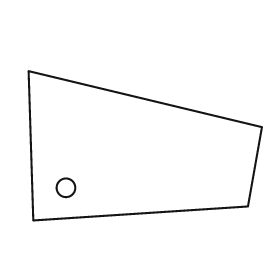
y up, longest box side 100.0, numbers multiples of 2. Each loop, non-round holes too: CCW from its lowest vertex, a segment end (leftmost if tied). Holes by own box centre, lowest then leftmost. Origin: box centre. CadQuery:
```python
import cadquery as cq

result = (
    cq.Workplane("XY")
    .moveTo(-48.0, -32.0)
    .lineTo(44.0, -26.0)
    .lineTo(50.0, 8.0)
    .lineTo(-50.0, 32.0)
    .close()
    .moveTo(-34.0, -18.0)
    .circle(4.0)
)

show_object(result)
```